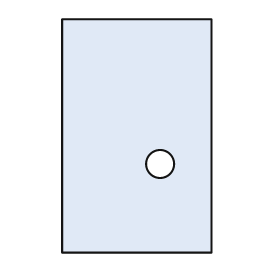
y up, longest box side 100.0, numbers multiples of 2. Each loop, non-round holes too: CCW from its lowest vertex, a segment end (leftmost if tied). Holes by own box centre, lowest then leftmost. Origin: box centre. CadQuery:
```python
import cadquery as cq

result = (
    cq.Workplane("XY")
    .moveTo(-32.0, -50.0)
    .lineTo(32.0, -50.0)
    .lineTo(32.0, 50.0)
    .lineTo(-32.0, 50.0)
    .close()
    .moveTo(10.0, -12.0)
    .circle(6.0)
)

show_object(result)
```